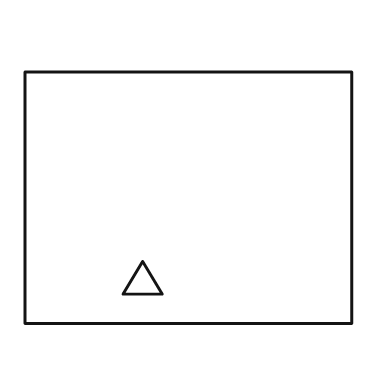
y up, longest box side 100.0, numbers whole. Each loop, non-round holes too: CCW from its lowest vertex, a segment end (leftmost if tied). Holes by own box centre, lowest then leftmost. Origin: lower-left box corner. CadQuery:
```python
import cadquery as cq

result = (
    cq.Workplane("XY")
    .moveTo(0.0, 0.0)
    .lineTo(100.0, 0.0)
    .lineTo(100.0, 77.0)
    .lineTo(0.0, 77.0)
    .close()
    .moveTo(30.0, 9.0)
    .lineTo(42.0, 9.0)
    .lineTo(36.0, 19.0)
    .close()
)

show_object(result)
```